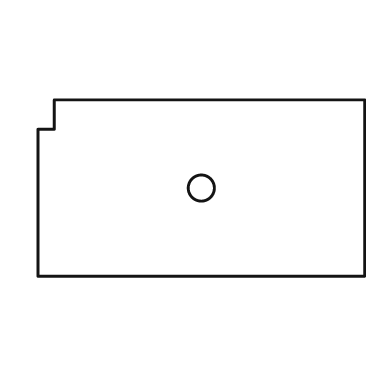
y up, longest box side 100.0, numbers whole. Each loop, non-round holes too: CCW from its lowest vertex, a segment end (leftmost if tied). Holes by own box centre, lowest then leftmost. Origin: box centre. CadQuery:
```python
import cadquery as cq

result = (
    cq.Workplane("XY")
    .moveTo(-50.0, -27.0)
    .lineTo(50.0, -27.0)
    .lineTo(50.0, 27.0)
    .lineTo(-45.0, 27.0)
    .lineTo(-45.0, 18.0)
    .lineTo(-50.0, 18.0)
    .close()
    .moveTo(0.0, 0.0)
    .circle(4.0)
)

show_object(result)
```